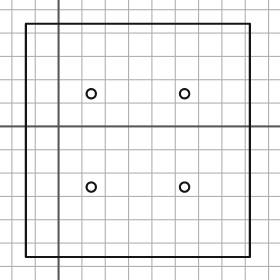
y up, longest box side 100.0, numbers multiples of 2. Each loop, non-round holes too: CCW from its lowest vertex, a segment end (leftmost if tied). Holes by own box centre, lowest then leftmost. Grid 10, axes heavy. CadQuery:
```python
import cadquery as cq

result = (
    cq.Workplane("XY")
    .moveTo(-14.0, -56.0)
    .lineTo(82.0, -56.0)
    .lineTo(82.0, 44.0)
    .lineTo(-14.0, 44.0)
    .close()
    .moveTo(14.0, -26.0)
    .circle(2.0)
    .moveTo(54.0, -26.0)
    .circle(2.0)
    .moveTo(14.0, 14.0)
    .circle(2.0)
    .moveTo(54.0, 14.0)
    .circle(2.0)
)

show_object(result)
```